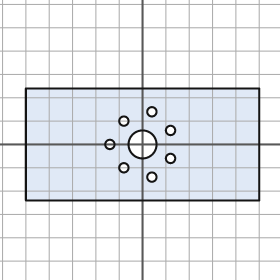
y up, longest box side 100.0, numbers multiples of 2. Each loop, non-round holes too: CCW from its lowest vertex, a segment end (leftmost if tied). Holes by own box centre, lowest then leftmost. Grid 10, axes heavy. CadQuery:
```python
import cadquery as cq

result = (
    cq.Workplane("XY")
    .moveTo(-50.0, -24.0)
    .lineTo(50.0, -24.0)
    .lineTo(50.0, 24.0)
    .lineTo(-50.0, 24.0)
    .close()
    .moveTo(4.0, -14.0)
    .circle(2.0)
    .moveTo(-8.0, -10.0)
    .circle(2.0)
    .moveTo(12.0, -6.0)
    .circle(2.0)
    .moveTo(-14.0, 0.0)
    .circle(2.0)
    .moveTo(0.0, 0.0)
    .circle(6.0)
    .moveTo(12.0, 6.0)
    .circle(2.0)
    .moveTo(-8.0, 10.0)
    .circle(2.0)
    .moveTo(4.0, 14.0)
    .circle(2.0)
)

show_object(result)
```